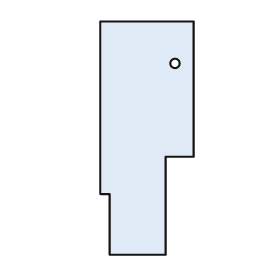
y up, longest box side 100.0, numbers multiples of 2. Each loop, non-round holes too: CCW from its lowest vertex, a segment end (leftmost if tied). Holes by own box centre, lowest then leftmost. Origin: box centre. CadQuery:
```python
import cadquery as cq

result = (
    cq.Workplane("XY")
    .moveTo(-16.0, -50.0)
    .lineTo(8.0, -50.0)
    .lineTo(8.0, -8.0)
    .lineTo(20.0, -8.0)
    .lineTo(20.0, 50.0)
    .lineTo(-20.0, 50.0)
    .lineTo(-20.0, -24.0)
    .lineTo(-16.0, -24.0)
    .close()
    .moveTo(12.0, 32.0)
    .circle(2.0)
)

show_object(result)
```